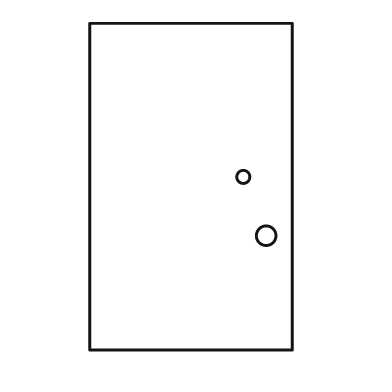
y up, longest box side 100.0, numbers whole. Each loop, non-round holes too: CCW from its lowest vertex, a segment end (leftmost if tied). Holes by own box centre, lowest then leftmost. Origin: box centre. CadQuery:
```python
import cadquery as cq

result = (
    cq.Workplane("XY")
    .moveTo(-31.0, -50.0)
    .lineTo(31.0, -50.0)
    .lineTo(31.0, 50.0)
    .lineTo(-31.0, 50.0)
    .close()
    .moveTo(23.0, -15.0)
    .circle(3.0)
    .moveTo(16.0, 3.0)
    .circle(2.0)
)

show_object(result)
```